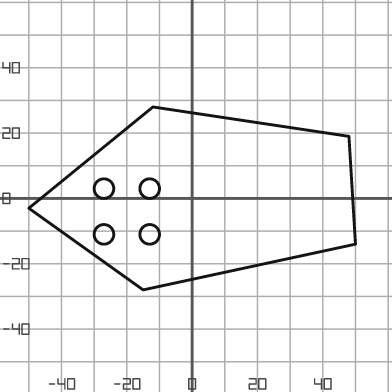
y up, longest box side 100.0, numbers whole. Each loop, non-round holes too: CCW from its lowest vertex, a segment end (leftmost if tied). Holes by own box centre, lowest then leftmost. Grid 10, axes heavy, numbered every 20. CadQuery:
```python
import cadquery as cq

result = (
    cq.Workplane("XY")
    .moveTo(-15.0, -28.0)
    .lineTo(50.0, -14.0)
    .lineTo(48.0, 19.0)
    .lineTo(-12.0, 28.0)
    .lineTo(-50.0, -3.0)
    .close()
    .moveTo(-27.0, -11.0)
    .circle(3.0)
    .moveTo(-13.0, -11.0)
    .circle(3.0)
    .moveTo(-27.0, 3.0)
    .circle(3.0)
    .moveTo(-13.0, 3.0)
    .circle(3.0)
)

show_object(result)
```